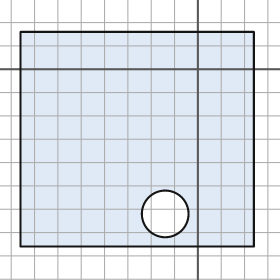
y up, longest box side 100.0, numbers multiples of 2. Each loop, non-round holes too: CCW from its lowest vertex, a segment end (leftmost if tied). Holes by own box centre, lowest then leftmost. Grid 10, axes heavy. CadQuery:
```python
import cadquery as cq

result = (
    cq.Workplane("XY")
    .moveTo(-76.0, -76.0)
    .lineTo(24.0, -76.0)
    .lineTo(24.0, 16.0)
    .lineTo(-76.0, 16.0)
    .close()
    .moveTo(-14.0, -62.0)
    .circle(10.0)
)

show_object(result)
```